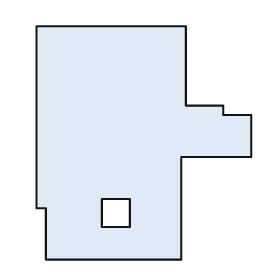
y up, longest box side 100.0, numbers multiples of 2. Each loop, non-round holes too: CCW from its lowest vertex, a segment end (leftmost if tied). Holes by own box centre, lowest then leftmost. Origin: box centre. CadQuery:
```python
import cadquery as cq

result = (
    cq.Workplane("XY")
    .moveTo(-42.0, -50.0)
    .lineTo(16.0, -50.0)
    .lineTo(16.0, -6.0)
    .lineTo(46.0, -6.0)
    .lineTo(46.0, 12.0)
    .lineTo(34.0, 12.0)
    .lineTo(34.0, 16.0)
    .lineTo(18.0, 16.0)
    .lineTo(18.0, 50.0)
    .lineTo(-46.0, 50.0)
    .lineTo(-46.0, -28.0)
    .lineTo(-42.0, -28.0)
    .close()
    .moveTo(-18.0, -36.0)
    .lineTo(-6.0, -36.0)
    .lineTo(-6.0, -24.0)
    .lineTo(-18.0, -24.0)
    .close()
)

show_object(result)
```